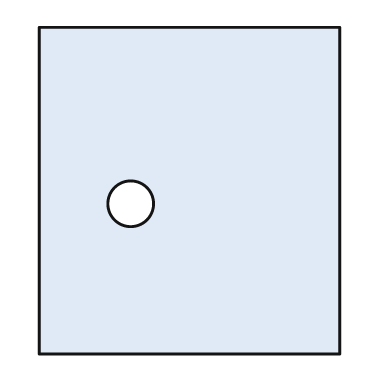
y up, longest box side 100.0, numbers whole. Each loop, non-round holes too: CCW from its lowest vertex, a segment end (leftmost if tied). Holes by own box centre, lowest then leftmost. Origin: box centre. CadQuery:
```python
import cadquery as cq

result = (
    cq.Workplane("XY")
    .moveTo(-46.0, -50.0)
    .lineTo(46.0, -50.0)
    .lineTo(46.0, 50.0)
    .lineTo(-46.0, 50.0)
    .close()
    .moveTo(-18.0, -4.0)
    .circle(7.0)
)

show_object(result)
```